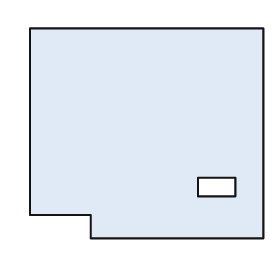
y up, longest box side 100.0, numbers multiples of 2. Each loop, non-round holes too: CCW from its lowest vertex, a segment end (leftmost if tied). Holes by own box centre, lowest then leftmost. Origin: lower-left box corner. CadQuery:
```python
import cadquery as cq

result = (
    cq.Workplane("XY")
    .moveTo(26.0, 0.0)
    .lineTo(100.0, 0.0)
    .lineTo(100.0, 90.0)
    .lineTo(0.0, 90.0)
    .lineTo(0.0, 10.0)
    .lineTo(26.0, 10.0)
    .close()
    .moveTo(72.0, 18.0)
    .lineTo(88.0, 18.0)
    .lineTo(88.0, 26.0)
    .lineTo(72.0, 26.0)
    .close()
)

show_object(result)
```